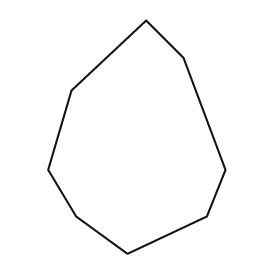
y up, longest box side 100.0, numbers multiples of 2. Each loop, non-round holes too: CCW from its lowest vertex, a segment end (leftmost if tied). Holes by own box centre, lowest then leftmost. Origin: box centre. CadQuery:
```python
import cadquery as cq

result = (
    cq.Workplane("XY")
    .moveTo(-4.0, -50.0)
    .lineTo(30.0, -34.0)
    .lineTo(38.0, -14.0)
    .lineTo(20.0, 34.0)
    .lineTo(4.0, 50.0)
    .lineTo(-28.0, 20.0)
    .lineTo(-38.0, -14.0)
    .lineTo(-26.0, -34.0)
    .close()
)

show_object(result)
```